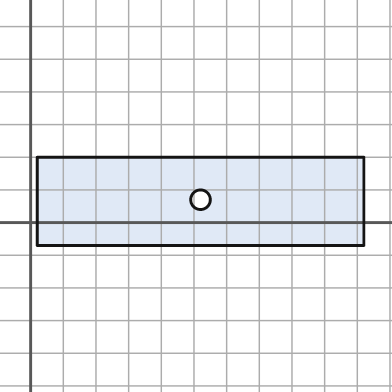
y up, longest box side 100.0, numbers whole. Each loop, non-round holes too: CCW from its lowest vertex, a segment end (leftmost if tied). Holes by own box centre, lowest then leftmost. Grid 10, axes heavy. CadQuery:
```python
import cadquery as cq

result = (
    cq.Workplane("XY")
    .moveTo(2.0, -7.0)
    .lineTo(102.0, -7.0)
    .lineTo(102.0, 20.0)
    .lineTo(2.0, 20.0)
    .close()
    .moveTo(52.0, 7.0)
    .circle(3.0)
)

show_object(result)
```